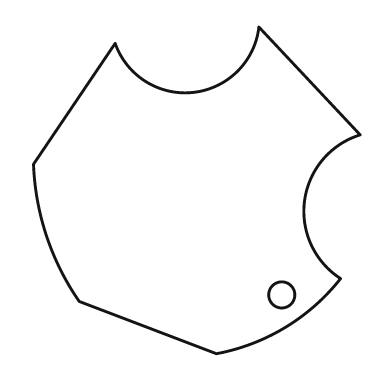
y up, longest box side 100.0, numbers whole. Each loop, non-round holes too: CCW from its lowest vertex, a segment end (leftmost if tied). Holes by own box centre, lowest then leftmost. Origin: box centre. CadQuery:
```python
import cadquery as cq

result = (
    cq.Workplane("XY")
    .moveTo(6.0, -50.0)
    .threePointArc((27.0, -42.0), (44.0, -27.0))
    .threePointArc((33.0, -3.0), (50.0, 17.0))
    .lineTo(19.0, 50.0)
    .threePointArc((-1.0, 30.0), (-25.0, 45.0))
    .lineTo(-50.0, 8.0)
    .threePointArc((-46.0, -14.0), (-36.0, -34.0))
    .close()
    .moveTo(26.0, -32.0)
    .circle(4.0)
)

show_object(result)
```